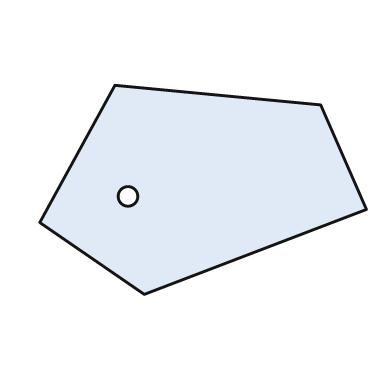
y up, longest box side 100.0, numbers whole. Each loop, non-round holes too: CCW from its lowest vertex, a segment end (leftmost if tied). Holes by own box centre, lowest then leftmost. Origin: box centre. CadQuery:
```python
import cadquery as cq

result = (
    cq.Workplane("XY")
    .moveTo(-18.0, -32.0)
    .lineTo(50.0, -6.0)
    .lineTo(36.0, 26.0)
    .lineTo(-27.0, 32.0)
    .lineTo(-50.0, -10.0)
    .close()
    .moveTo(-23.0, -2.0)
    .circle(3.0)
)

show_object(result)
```